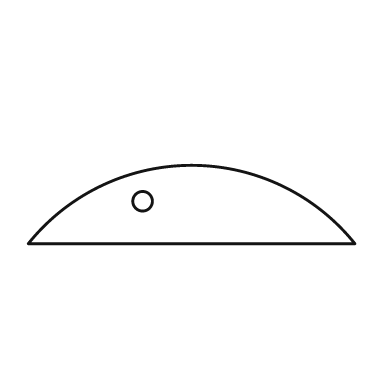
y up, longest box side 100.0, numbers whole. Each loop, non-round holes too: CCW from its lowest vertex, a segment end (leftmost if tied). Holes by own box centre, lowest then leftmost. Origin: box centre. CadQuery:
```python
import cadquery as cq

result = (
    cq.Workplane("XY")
    .moveTo(-50.0, -12.0)
    .lineTo(50.0, -12.0)
    .threePointArc((0.0, 12.0), (-50.0, -12.0))
    .close()
    .moveTo(-15.0, 1.0)
    .circle(3.0)
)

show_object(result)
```